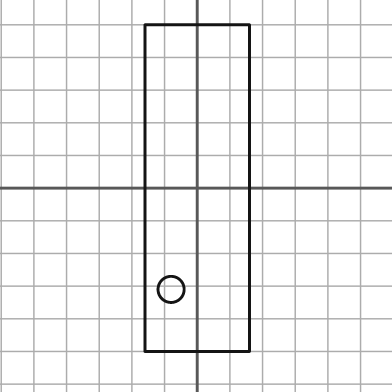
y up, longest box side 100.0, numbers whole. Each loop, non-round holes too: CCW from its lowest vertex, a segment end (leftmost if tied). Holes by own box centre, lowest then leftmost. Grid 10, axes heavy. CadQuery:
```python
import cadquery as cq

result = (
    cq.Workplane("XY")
    .moveTo(-16.0, -50.0)
    .lineTo(16.0, -50.0)
    .lineTo(16.0, 50.0)
    .lineTo(-16.0, 50.0)
    .close()
    .moveTo(-8.0, -31.0)
    .circle(4.0)
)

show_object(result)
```